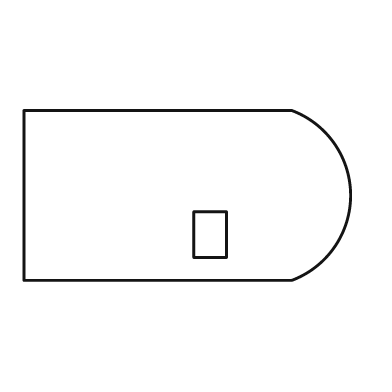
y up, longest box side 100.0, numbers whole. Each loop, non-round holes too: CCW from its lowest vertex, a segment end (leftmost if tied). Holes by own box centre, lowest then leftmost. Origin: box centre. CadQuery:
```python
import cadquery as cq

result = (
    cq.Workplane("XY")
    .moveTo(-50.0, -26.0)
    .lineTo(32.0, -26.0)
    .threePointArc((50.0, 0.0), (32.0, 26.0))
    .lineTo(-50.0, 26.0)
    .close()
    .moveTo(2.0, -19.0)
    .lineTo(12.0, -19.0)
    .lineTo(12.0, -5.0)
    .lineTo(2.0, -5.0)
    .close()
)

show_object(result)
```